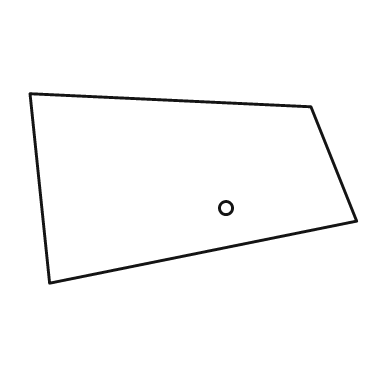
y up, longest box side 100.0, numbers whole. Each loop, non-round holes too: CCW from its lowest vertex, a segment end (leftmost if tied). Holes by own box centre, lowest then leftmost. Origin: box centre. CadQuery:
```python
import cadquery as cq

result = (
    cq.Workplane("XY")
    .moveTo(-44.0, -29.0)
    .lineTo(50.0, -10.0)
    .lineTo(36.0, 25.0)
    .lineTo(-50.0, 29.0)
    .close()
    .moveTo(10.0, -6.0)
    .circle(2.0)
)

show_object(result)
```